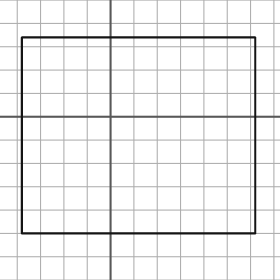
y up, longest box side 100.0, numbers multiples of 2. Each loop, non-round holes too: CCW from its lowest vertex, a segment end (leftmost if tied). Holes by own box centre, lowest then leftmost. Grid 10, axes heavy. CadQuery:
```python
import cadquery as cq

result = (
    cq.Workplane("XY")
    .moveTo(-38.0, -50.0)
    .lineTo(62.0, -50.0)
    .lineTo(62.0, 34.0)
    .lineTo(-38.0, 34.0)
    .close()
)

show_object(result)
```